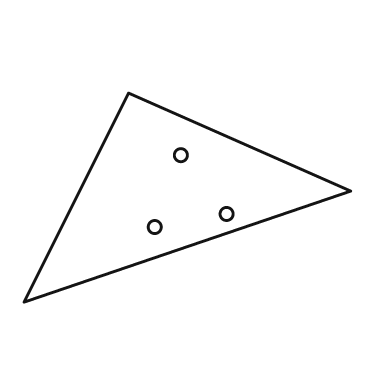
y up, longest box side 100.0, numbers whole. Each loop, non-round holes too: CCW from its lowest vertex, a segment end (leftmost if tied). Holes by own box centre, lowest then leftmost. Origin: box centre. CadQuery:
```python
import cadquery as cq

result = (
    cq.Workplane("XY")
    .moveTo(-50.0, -32.0)
    .lineTo(50.0, 2.0)
    .lineTo(-18.0, 32.0)
    .close()
    .moveTo(-10.0, -9.0)
    .circle(2.0)
    .moveTo(12.0, -5.0)
    .circle(2.0)
    .moveTo(-2.0, 13.0)
    .circle(2.0)
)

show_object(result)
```